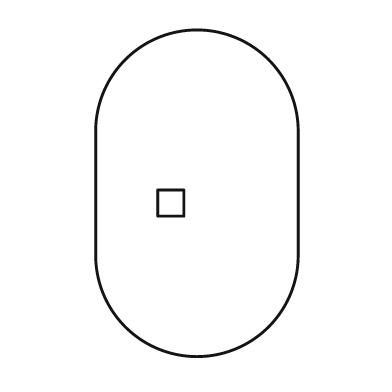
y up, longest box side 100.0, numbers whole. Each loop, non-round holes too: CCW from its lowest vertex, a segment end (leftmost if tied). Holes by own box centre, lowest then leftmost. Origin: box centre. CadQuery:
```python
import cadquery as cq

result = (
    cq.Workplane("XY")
    .moveTo(-31.0, -19.0)
    .threePointArc((0.0, -50.0), (31.0, -19.0))
    .lineTo(31.0, 19.0)
    .threePointArc((0.0, 50.0), (-31.0, 19.0))
    .close()
    .moveTo(-12.0, -7.0)
    .lineTo(-4.0, -7.0)
    .lineTo(-4.0, 1.0)
    .lineTo(-12.0, 1.0)
    .close()
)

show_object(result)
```